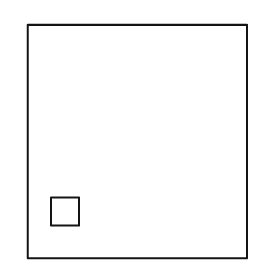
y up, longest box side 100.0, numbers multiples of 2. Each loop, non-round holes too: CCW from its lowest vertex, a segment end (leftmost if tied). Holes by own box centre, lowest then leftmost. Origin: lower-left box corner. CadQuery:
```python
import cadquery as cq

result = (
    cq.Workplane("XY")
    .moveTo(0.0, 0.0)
    .lineTo(94.0, 0.0)
    .lineTo(94.0, 100.0)
    .lineTo(0.0, 100.0)
    .close()
    .moveTo(10.0, 14.0)
    .lineTo(22.0, 14.0)
    .lineTo(22.0, 26.0)
    .lineTo(10.0, 26.0)
    .close()
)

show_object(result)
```